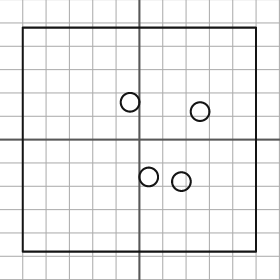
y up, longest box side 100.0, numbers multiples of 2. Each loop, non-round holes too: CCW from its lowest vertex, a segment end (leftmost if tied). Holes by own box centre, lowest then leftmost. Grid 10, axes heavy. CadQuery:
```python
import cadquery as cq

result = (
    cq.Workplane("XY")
    .moveTo(-50.0, -48.0)
    .lineTo(50.0, -48.0)
    .lineTo(50.0, 48.0)
    .lineTo(-50.0, 48.0)
    .close()
    .moveTo(18.0, -18.0)
    .circle(4.0)
    .moveTo(4.0, -16.0)
    .circle(4.0)
    .moveTo(26.0, 12.0)
    .circle(4.0)
    .moveTo(-4.0, 16.0)
    .circle(4.0)
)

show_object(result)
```